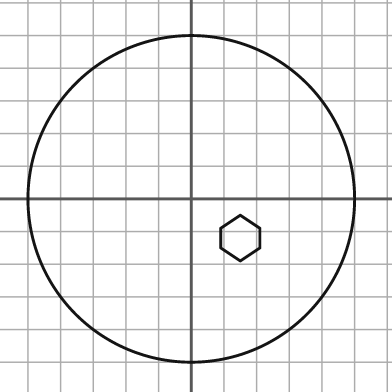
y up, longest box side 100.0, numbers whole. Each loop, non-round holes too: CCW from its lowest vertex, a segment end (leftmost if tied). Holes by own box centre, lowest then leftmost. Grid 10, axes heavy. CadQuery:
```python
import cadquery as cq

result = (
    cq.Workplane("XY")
    .moveTo(0.0, 0.0)
    .circle(50.0)
    .moveTo(15.0, -19.0)
    .lineTo(21.0, -15.0)
    .lineTo(21.0, -9.0)
    .lineTo(15.0, -5.0)
    .lineTo(9.0, -9.0)
    .lineTo(9.0, -15.0)
    .close()
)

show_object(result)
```